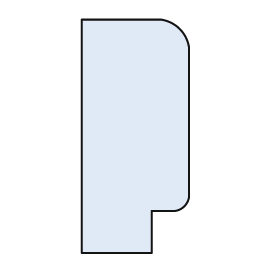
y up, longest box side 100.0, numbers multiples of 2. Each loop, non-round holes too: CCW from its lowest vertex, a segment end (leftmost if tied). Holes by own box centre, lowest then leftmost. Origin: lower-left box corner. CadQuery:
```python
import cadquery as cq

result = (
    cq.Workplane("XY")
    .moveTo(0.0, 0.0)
    .lineTo(30.0, 0.0)
    .lineTo(30.0, 18.0)
    .lineTo(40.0, 18.0)
    .threePointArc((44.0, 20.0), (46.0, 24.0))
    .lineTo(46.0, 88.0)
    .threePointArc((42.0, 96.0), (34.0, 100.0))
    .lineTo(0.0, 100.0)
    .close()
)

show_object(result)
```